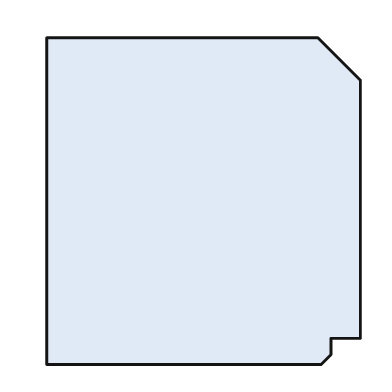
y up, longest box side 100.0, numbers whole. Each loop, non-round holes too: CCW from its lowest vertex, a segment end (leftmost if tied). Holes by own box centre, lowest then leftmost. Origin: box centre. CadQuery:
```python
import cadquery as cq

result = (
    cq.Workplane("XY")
    .moveTo(-48.0, -50.0)
    .lineTo(36.0, -50.0)
    .lineTo(39.0, -47.0)
    .lineTo(39.0, -42.0)
    .lineTo(48.0, -42.0)
    .lineTo(48.0, 37.0)
    .lineTo(35.0, 50.0)
    .lineTo(-48.0, 50.0)
    .close()
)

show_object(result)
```